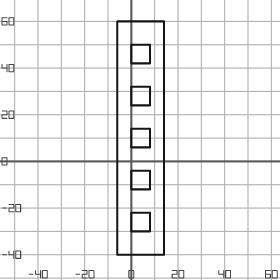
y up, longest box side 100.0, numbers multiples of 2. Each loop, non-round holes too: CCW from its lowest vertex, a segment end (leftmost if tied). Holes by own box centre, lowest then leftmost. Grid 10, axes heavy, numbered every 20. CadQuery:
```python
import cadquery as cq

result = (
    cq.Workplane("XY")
    .moveTo(-6.0, -40.0)
    .lineTo(14.0, -40.0)
    .lineTo(14.0, 60.0)
    .lineTo(-6.0, 60.0)
    .close()
    .moveTo(0.0, -30.0)
    .lineTo(8.0, -30.0)
    .lineTo(8.0, -22.0)
    .lineTo(0.0, -22.0)
    .close()
    .moveTo(0.0, -12.0)
    .lineTo(8.0, -12.0)
    .lineTo(8.0, -4.0)
    .lineTo(0.0, -4.0)
    .close()
    .moveTo(0.0, 6.0)
    .lineTo(8.0, 6.0)
    .lineTo(8.0, 14.0)
    .lineTo(0.0, 14.0)
    .close()
    .moveTo(0.0, 24.0)
    .lineTo(8.0, 24.0)
    .lineTo(8.0, 32.0)
    .lineTo(0.0, 32.0)
    .close()
    .moveTo(0.0, 42.0)
    .lineTo(8.0, 42.0)
    .lineTo(8.0, 50.0)
    .lineTo(0.0, 50.0)
    .close()
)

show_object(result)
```